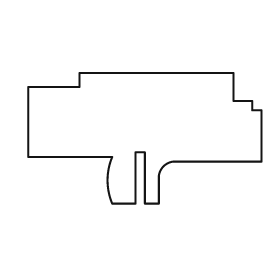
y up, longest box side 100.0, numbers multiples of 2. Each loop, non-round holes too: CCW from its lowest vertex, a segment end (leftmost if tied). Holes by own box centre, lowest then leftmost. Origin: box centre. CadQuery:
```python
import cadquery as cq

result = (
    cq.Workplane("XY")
    .moveTo(-14.0, -28.0)
    .lineTo(-4.0, -28.0)
    .lineTo(-4.0, -6.0)
    .lineTo(0.0, -6.0)
    .lineTo(0.0, -28.0)
    .lineTo(6.0, -28.0)
    .lineTo(6.0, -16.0)
    .threePointArc((8.0, -12.0), (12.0, -10.0))
    .lineTo(50.0, -10.0)
    .lineTo(50.0, 12.0)
    .lineTo(46.0, 12.0)
    .lineTo(46.0, 16.0)
    .lineTo(38.0, 16.0)
    .lineTo(38.0, 28.0)
    .lineTo(-28.0, 28.0)
    .lineTo(-28.0, 22.0)
    .lineTo(-50.0, 22.0)
    .lineTo(-50.0, -8.0)
    .lineTo(-14.0, -8.0)
    .threePointArc((-16.0, -18.0), (-14.0, -28.0))
    .close()
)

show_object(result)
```